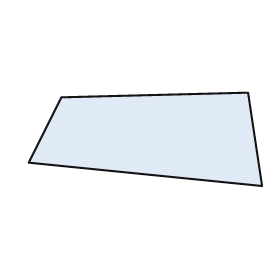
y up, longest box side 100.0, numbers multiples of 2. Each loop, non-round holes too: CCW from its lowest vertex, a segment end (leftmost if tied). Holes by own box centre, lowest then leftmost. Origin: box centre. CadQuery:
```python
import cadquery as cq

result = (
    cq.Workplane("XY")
    .moveTo(50.0, -20.0)
    .lineTo(44.0, 20.0)
    .lineTo(-36.0, 18.0)
    .lineTo(-50.0, -10.0)
    .close()
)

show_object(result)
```